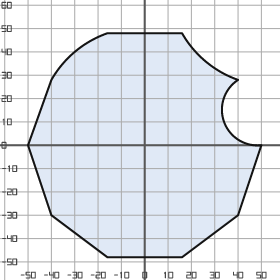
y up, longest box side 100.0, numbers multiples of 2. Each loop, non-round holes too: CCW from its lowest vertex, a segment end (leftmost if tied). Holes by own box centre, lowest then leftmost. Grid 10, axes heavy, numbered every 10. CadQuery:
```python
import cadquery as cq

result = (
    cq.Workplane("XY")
    .moveTo(-16.0, -48.0)
    .lineTo(16.0, -48.0)
    .lineTo(40.0, -30.0)
    .lineTo(50.0, 0.0)
    .threePointArc((34.0, 10.0), (40.0, 28.0))
    .threePointArc((26.0, 36.0), (16.0, 48.0))
    .lineTo(-16.0, 48.0)
    .threePointArc((-30.0, 40.0), (-40.0, 28.0))
    .lineTo(-50.0, 0.0)
    .lineTo(-40.0, -30.0)
    .close()
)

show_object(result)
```